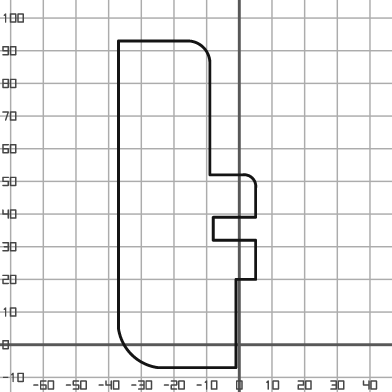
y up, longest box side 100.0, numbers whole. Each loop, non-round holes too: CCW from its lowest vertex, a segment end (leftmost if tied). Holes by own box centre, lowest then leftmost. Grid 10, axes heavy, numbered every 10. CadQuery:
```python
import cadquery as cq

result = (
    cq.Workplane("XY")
    .moveTo(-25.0, -7.0)
    .lineTo(-1.0, -7.0)
    .lineTo(-1.0, 20.0)
    .lineTo(5.0, 20.0)
    .lineTo(5.0, 32.0)
    .lineTo(-8.0, 32.0)
    .lineTo(-8.0, 39.0)
    .lineTo(5.0, 39.0)
    .lineTo(5.0, 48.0)
    .threePointArc((4.0, 51.0), (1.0, 52.0))
    .lineTo(-9.0, 52.0)
    .lineTo(-9.0, 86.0)
    .threePointArc((-11.0, 91.0), (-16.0, 93.0))
    .lineTo(-37.0, 93.0)
    .lineTo(-37.0, 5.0)
    .threePointArc((-33.0, -3.0), (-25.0, -7.0))
    .close()
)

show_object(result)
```